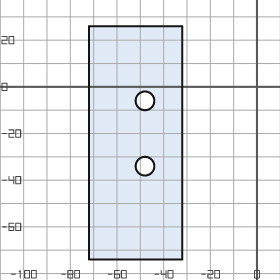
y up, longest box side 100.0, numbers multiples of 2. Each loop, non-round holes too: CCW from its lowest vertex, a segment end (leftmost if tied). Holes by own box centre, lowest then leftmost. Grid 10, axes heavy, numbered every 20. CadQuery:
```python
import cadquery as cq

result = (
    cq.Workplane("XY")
    .moveTo(-72.0, -74.0)
    .lineTo(-32.0, -74.0)
    .lineTo(-32.0, 26.0)
    .lineTo(-72.0, 26.0)
    .close()
    .moveTo(-48.0, -34.0)
    .circle(4.0)
    .moveTo(-48.0, -6.0)
    .circle(4.0)
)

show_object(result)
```